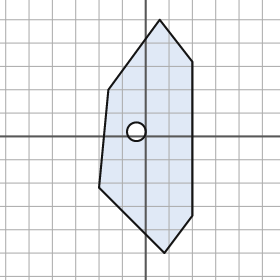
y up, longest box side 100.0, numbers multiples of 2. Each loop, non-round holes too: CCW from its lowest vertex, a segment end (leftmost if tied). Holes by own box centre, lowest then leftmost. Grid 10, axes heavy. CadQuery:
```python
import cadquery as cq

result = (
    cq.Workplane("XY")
    .moveTo(8.0, -50.0)
    .lineTo(20.0, -34.0)
    .lineTo(20.0, 32.0)
    .lineTo(6.0, 50.0)
    .lineTo(-16.0, 20.0)
    .lineTo(-20.0, -22.0)
    .close()
    .moveTo(-4.0, 2.0)
    .circle(4.0)
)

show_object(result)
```